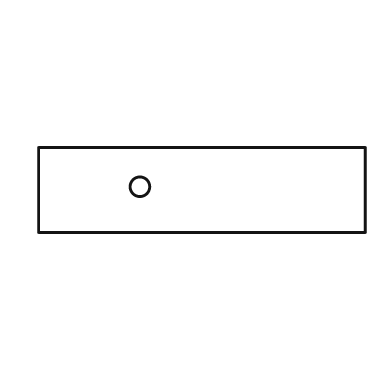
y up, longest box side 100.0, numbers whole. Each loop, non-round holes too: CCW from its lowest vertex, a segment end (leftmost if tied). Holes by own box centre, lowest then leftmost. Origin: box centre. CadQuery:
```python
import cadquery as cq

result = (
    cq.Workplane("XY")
    .moveTo(-50.0, -13.0)
    .lineTo(50.0, -13.0)
    .lineTo(50.0, 13.0)
    .lineTo(-50.0, 13.0)
    .close()
    .moveTo(-19.0, 1.0)
    .circle(3.0)
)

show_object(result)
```